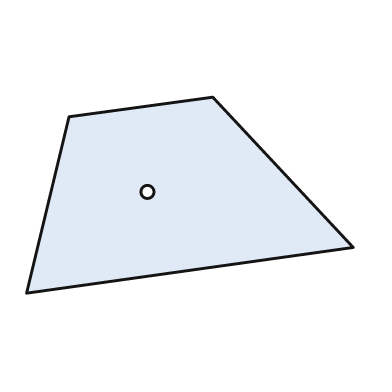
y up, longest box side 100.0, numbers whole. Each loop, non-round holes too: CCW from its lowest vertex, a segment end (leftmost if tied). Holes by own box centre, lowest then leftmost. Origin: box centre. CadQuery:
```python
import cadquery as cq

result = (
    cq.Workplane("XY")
    .moveTo(-50.0, -30.0)
    .lineTo(50.0, -16.0)
    .lineTo(7.0, 30.0)
    .lineTo(-37.0, 24.0)
    .close()
    .moveTo(-13.0, 1.0)
    .circle(2.0)
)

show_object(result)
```